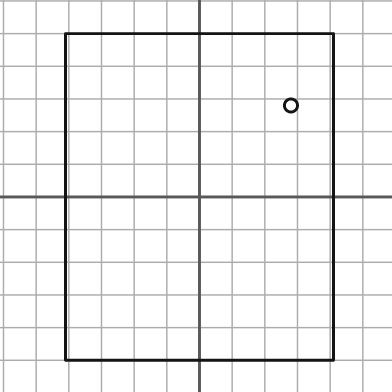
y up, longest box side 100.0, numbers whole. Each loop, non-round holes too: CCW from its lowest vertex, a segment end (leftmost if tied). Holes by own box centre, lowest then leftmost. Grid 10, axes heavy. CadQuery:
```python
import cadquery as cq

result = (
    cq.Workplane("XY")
    .moveTo(-41.0, -50.0)
    .lineTo(41.0, -50.0)
    .lineTo(41.0, 50.0)
    .lineTo(-41.0, 50.0)
    .close()
    .moveTo(28.0, 28.0)
    .circle(2.0)
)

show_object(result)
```